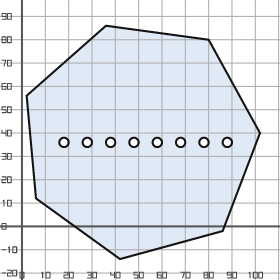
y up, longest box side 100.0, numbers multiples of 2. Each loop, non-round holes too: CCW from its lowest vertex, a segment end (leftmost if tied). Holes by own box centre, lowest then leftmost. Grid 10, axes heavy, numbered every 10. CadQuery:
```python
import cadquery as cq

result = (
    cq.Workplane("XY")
    .moveTo(42.0, -14.0)
    .lineTo(86.0, -2.0)
    .lineTo(102.0, 40.0)
    .lineTo(80.0, 80.0)
    .lineTo(36.0, 86.0)
    .lineTo(2.0, 56.0)
    .lineTo(6.0, 12.0)
    .close()
    .moveTo(18.0, 36.0)
    .circle(2.0)
    .moveTo(28.0, 36.0)
    .circle(2.0)
    .moveTo(38.0, 36.0)
    .circle(2.0)
    .moveTo(48.0, 36.0)
    .circle(2.0)
    .moveTo(58.0, 36.0)
    .circle(2.0)
    .moveTo(68.0, 36.0)
    .circle(2.0)
    .moveTo(78.0, 36.0)
    .circle(2.0)
    .moveTo(88.0, 36.0)
    .circle(2.0)
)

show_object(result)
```